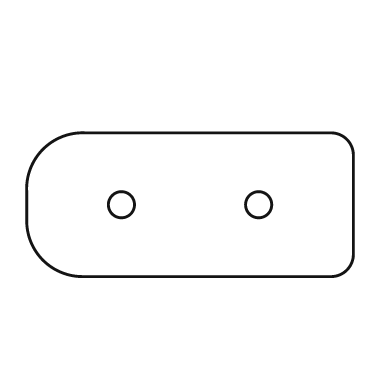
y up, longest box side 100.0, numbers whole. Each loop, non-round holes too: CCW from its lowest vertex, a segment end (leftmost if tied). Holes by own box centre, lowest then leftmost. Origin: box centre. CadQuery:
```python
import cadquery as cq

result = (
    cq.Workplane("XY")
    .moveTo(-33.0, -22.0)
    .lineTo(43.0, -22.0)
    .threePointArc((48.0, -20.0), (50.0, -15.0))
    .lineTo(50.0, 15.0)
    .threePointArc((48.0, 20.0), (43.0, 22.0))
    .lineTo(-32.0, 22.0)
    .threePointArc((-45.0, 17.0), (-50.0, 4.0))
    .lineTo(-50.0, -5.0)
    .threePointArc((-45.0, -17.0), (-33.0, -22.0))
    .close()
    .moveTo(-21.0, 0.0)
    .circle(4.0)
    .moveTo(21.0, 0.0)
    .circle(4.0)
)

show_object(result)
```